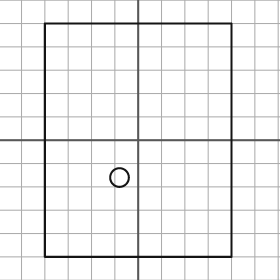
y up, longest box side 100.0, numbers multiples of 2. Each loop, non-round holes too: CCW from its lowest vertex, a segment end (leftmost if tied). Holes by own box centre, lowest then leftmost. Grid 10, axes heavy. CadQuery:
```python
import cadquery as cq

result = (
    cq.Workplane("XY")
    .moveTo(-40.0, -50.0)
    .lineTo(40.0, -50.0)
    .lineTo(40.0, 50.0)
    .lineTo(-40.0, 50.0)
    .close()
    .moveTo(-8.0, -16.0)
    .circle(4.0)
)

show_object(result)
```